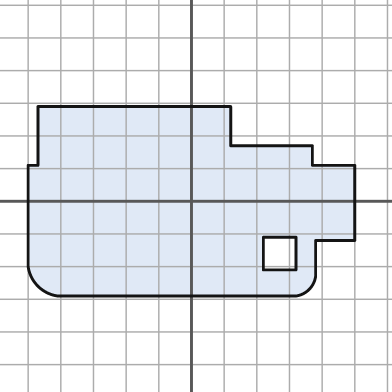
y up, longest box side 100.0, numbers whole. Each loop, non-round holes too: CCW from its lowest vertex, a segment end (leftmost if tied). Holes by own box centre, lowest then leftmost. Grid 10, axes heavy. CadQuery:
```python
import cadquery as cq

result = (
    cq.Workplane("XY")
    .moveTo(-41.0, -29.0)
    .lineTo(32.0, -29.0)
    .threePointArc((36.0, -27.0), (38.0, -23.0))
    .lineTo(38.0, -12.0)
    .lineTo(50.0, -12.0)
    .lineTo(50.0, 11.0)
    .lineTo(37.0, 11.0)
    .lineTo(37.0, 17.0)
    .lineTo(12.0, 17.0)
    .lineTo(12.0, 29.0)
    .lineTo(-47.0, 29.0)
    .lineTo(-47.0, 11.0)
    .lineTo(-50.0, 11.0)
    .lineTo(-50.0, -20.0)
    .threePointArc((-47.0, -26.0), (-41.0, -29.0))
    .close()
    .moveTo(22.0, -21.0)
    .lineTo(32.0, -21.0)
    .lineTo(32.0, -11.0)
    .lineTo(22.0, -11.0)
    .close()
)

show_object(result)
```